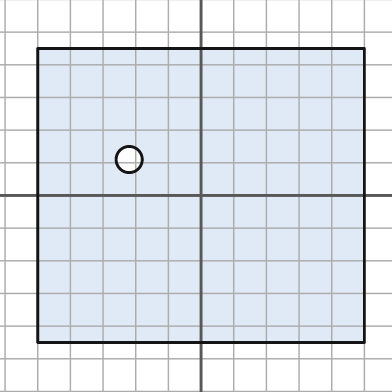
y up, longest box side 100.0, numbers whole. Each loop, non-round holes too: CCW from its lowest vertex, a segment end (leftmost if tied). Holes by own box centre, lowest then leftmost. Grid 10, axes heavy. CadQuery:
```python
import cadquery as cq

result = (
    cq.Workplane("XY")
    .moveTo(-50.0, -45.0)
    .lineTo(50.0, -45.0)
    .lineTo(50.0, 45.0)
    .lineTo(-50.0, 45.0)
    .close()
    .moveTo(-22.0, 11.0)
    .circle(4.0)
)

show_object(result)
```